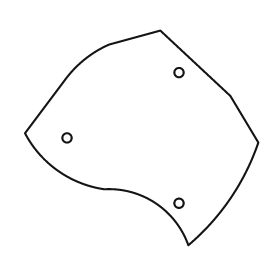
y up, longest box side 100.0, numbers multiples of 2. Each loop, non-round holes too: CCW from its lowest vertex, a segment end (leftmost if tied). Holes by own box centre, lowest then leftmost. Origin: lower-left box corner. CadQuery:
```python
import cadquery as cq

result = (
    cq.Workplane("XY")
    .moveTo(70.0, 0.0)
    .threePointArc((88.0, 20.0), (100.0, 44.0))
    .lineTo(88.0, 64.0)
    .lineTo(58.0, 92.0)
    .lineTo(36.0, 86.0)
    .threePointArc((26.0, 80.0), (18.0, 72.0))
    .lineTo(0.0, 48.0)
    .threePointArc((14.0, 32.0), (34.0, 24.0))
    .threePointArc((56.0, 18.0), (70.0, 0.0))
    .close()
    .moveTo(66.0, 18.0)
    .circle(2.0)
    .moveTo(18.0, 46.0)
    .circle(2.0)
    .moveTo(66.0, 74.0)
    .circle(2.0)
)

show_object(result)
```